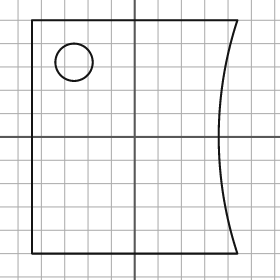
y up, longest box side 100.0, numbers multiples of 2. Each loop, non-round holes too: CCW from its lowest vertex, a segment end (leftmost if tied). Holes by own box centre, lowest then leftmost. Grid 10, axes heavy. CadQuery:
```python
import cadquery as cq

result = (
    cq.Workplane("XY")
    .moveTo(-44.0, -50.0)
    .lineTo(44.0, -50.0)
    .threePointArc((36.0, 0.0), (44.0, 50.0))
    .lineTo(-44.0, 50.0)
    .close()
    .moveTo(-26.0, 32.0)
    .circle(8.0)
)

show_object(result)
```